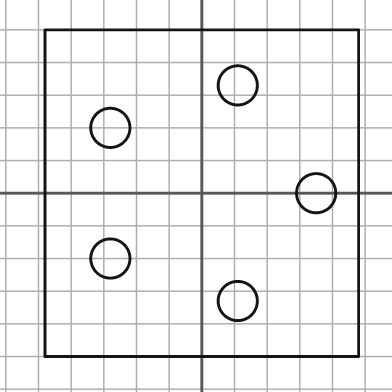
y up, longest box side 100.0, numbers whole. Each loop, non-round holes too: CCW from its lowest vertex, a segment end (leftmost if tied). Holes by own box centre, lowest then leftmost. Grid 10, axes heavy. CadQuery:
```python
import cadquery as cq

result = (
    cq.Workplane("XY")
    .moveTo(-48.0, -50.0)
    .lineTo(48.0, -50.0)
    .lineTo(48.0, 50.0)
    .lineTo(-48.0, 50.0)
    .close()
    .moveTo(11.0, -33.0)
    .circle(6.0)
    .moveTo(-28.0, -20.0)
    .circle(6.0)
    .moveTo(35.0, 0.0)
    .circle(6.0)
    .moveTo(-28.0, 20.0)
    .circle(6.0)
    .moveTo(11.0, 33.0)
    .circle(6.0)
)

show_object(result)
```